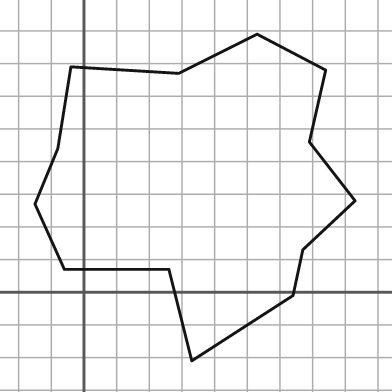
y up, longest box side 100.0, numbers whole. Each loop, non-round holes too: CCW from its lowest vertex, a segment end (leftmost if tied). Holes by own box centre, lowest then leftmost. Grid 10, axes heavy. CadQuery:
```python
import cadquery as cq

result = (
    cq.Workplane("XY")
    .moveTo(33.0, -21.0)
    .lineTo(64.0, -1.0)
    .lineTo(67.0, 13.0)
    .lineTo(83.0, 28.0)
    .lineTo(69.0, 46.0)
    .lineTo(74.0, 68.0)
    .lineTo(53.0, 79.0)
    .lineTo(29.0, 67.0)
    .lineTo(-4.0, 69.0)
    .lineTo(-8.0, 44.0)
    .lineTo(-15.0, 27.0)
    .lineTo(-6.0, 7.0)
    .lineTo(26.0, 7.0)
    .close()
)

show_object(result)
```